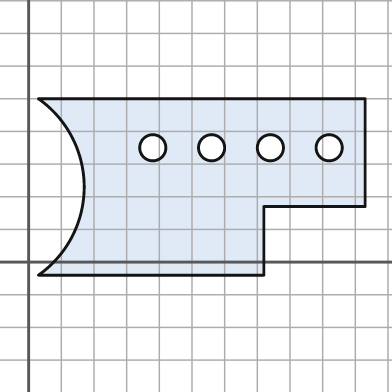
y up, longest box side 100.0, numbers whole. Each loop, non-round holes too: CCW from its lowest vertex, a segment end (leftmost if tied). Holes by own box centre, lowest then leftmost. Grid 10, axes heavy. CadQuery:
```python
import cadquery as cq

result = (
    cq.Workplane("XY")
    .moveTo(3.0, -4.0)
    .lineTo(72.0, -4.0)
    .lineTo(72.0, 17.0)
    .lineTo(103.0, 17.0)
    .lineTo(103.0, 50.0)
    .lineTo(3.0, 50.0)
    .threePointArc((17.0, 23.0), (3.0, -4.0))
    .close()
    .moveTo(38.0, 35.0)
    .circle(4.0)
    .moveTo(56.0, 35.0)
    .circle(4.0)
    .moveTo(74.0, 35.0)
    .circle(4.0)
    .moveTo(92.0, 35.0)
    .circle(4.0)
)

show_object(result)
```